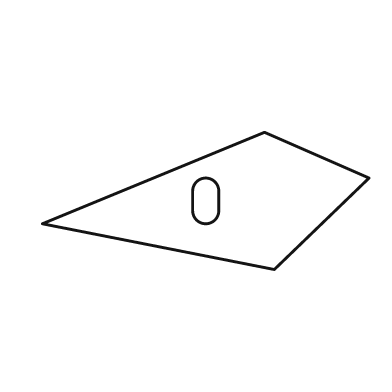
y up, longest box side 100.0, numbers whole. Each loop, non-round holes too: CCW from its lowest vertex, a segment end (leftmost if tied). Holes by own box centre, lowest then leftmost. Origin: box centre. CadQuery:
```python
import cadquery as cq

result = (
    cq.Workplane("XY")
    .moveTo(21.0, -21.0)
    .lineTo(50.0, 7.0)
    .lineTo(18.0, 21.0)
    .lineTo(-50.0, -7.0)
    .close()
    .moveTo(-4.0, -3.0)
    .threePointArc((0.0, -7.0), (4.0, -3.0))
    .lineTo(4.0, 3.0)
    .threePointArc((0.0, 7.0), (-4.0, 3.0))
    .close()
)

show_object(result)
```